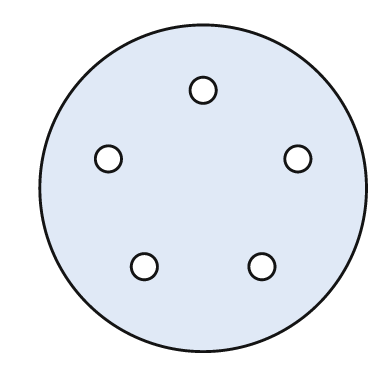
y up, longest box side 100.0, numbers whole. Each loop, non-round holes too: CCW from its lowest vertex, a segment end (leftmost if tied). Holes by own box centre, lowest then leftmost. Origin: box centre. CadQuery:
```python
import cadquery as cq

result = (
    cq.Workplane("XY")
    .moveTo(0.0, 0.0)
    .circle(50.0)
    .moveTo(-18.0, -24.0)
    .circle(4.0)
    .moveTo(18.0, -24.0)
    .circle(4.0)
    .moveTo(-29.0, 9.0)
    .circle(4.0)
    .moveTo(29.0, 9.0)
    .circle(4.0)
    .moveTo(0.0, 30.0)
    .circle(4.0)
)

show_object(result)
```